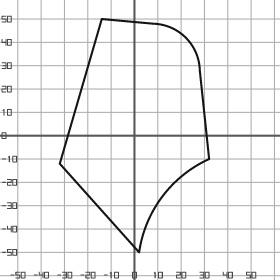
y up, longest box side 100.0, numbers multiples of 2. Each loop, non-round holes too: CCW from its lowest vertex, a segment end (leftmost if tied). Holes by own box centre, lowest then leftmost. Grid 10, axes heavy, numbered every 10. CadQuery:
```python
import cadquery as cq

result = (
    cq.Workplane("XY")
    .moveTo(2.0, -50.0)
    .threePointArc((12.0, -26.0), (32.0, -10.0))
    .lineTo(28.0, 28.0)
    .threePointArc((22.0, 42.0), (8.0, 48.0))
    .lineTo(-14.0, 50.0)
    .lineTo(-32.0, -12.0)
    .close()
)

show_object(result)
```